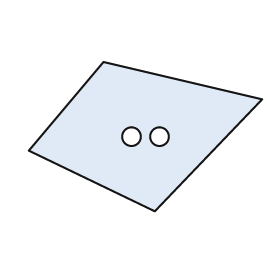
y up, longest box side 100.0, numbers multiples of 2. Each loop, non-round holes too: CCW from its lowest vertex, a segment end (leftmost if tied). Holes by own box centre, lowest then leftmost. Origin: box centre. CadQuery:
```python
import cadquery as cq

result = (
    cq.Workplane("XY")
    .moveTo(4.0, -32.0)
    .lineTo(50.0, 16.0)
    .lineTo(-18.0, 32.0)
    .lineTo(-50.0, -6.0)
    .close()
    .moveTo(-6.0, 0.0)
    .circle(4.0)
    .moveTo(6.0, 0.0)
    .circle(4.0)
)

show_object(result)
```